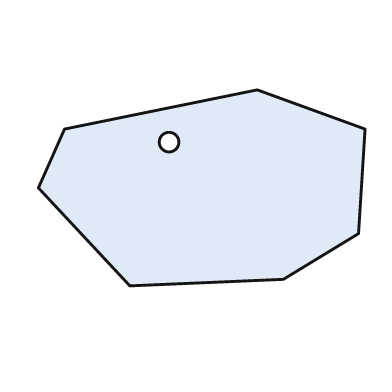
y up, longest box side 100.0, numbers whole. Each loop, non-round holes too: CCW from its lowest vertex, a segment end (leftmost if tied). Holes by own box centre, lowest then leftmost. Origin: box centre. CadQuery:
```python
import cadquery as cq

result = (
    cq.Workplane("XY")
    .moveTo(-22.0, -30.0)
    .lineTo(25.0, -28.0)
    .lineTo(48.0, -14.0)
    .lineTo(50.0, 18.0)
    .lineTo(17.0, 30.0)
    .lineTo(-42.0, 18.0)
    .lineTo(-50.0, 0.0)
    .close()
    .moveTo(-10.0, 14.0)
    .circle(3.0)
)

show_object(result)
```